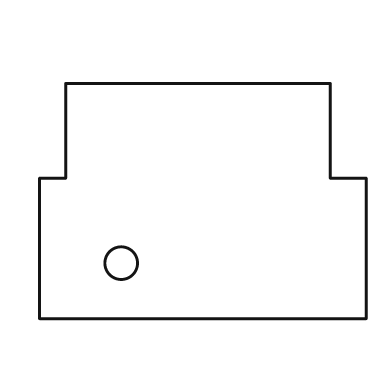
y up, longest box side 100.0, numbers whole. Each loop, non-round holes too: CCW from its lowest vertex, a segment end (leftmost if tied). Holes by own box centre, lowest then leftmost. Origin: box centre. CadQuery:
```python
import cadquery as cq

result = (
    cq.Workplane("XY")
    .moveTo(-50.0, -36.0)
    .lineTo(50.0, -36.0)
    .lineTo(50.0, 7.0)
    .lineTo(39.0, 7.0)
    .lineTo(39.0, 36.0)
    .lineTo(-42.0, 36.0)
    .lineTo(-42.0, 7.0)
    .lineTo(-50.0, 7.0)
    .close()
    .moveTo(-25.0, -19.0)
    .circle(5.0)
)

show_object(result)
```